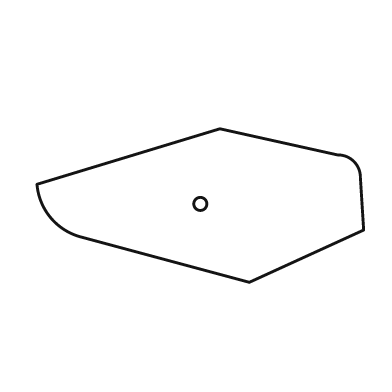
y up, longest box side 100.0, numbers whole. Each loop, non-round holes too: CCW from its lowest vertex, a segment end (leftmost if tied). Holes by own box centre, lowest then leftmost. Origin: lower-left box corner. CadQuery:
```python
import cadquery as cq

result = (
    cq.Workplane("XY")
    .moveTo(65.0, 0.0)
    .lineTo(100.0, 16.0)
    .lineTo(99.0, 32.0)
    .threePointArc((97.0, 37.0), (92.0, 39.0))
    .lineTo(56.0, 47.0)
    .lineTo(0.0, 30.0)
    .threePointArc((4.0, 20.0), (13.0, 14.0))
    .close()
    .moveTo(50.0, 24.0)
    .circle(2.0)
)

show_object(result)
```